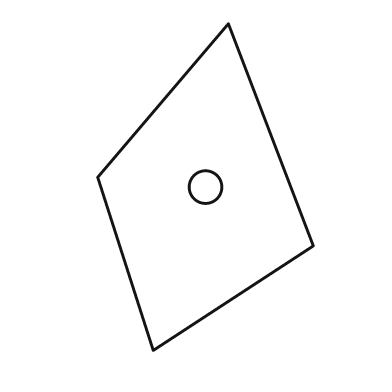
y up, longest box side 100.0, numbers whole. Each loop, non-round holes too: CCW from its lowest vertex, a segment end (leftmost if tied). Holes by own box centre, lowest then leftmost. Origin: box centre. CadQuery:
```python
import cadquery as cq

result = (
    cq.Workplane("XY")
    .moveTo(-16.0, -50.0)
    .lineTo(33.0, -18.0)
    .lineTo(7.0, 50.0)
    .lineTo(-33.0, 3.0)
    .close()
    .moveTo(0.0, 0.0)
    .circle(5.0)
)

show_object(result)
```